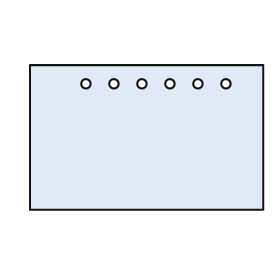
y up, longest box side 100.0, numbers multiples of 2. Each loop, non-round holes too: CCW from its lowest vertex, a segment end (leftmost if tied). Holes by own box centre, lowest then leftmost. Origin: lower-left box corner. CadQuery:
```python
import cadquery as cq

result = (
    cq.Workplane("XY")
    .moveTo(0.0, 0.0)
    .lineTo(100.0, 0.0)
    .lineTo(100.0, 62.0)
    .lineTo(0.0, 62.0)
    .close()
    .moveTo(24.0, 54.0)
    .circle(2.0)
    .moveTo(36.0, 54.0)
    .circle(2.0)
    .moveTo(48.0, 54.0)
    .circle(2.0)
    .moveTo(60.0, 54.0)
    .circle(2.0)
    .moveTo(72.0, 54.0)
    .circle(2.0)
    .moveTo(84.0, 54.0)
    .circle(2.0)
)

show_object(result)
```